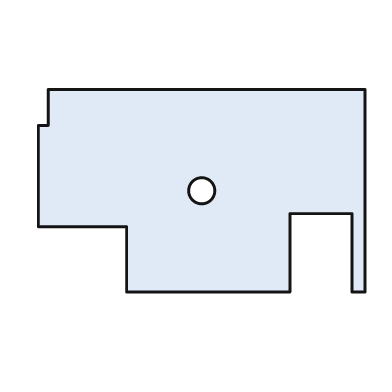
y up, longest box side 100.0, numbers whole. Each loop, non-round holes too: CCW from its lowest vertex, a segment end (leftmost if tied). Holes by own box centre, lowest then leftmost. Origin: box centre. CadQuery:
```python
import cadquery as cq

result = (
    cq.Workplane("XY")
    .moveTo(-23.0, -31.0)
    .lineTo(27.0, -31.0)
    .lineTo(27.0, -7.0)
    .lineTo(46.0, -7.0)
    .lineTo(46.0, -31.0)
    .lineTo(50.0, -31.0)
    .lineTo(50.0, 31.0)
    .lineTo(-47.0, 31.0)
    .lineTo(-47.0, 20.0)
    .lineTo(-50.0, 20.0)
    .lineTo(-50.0, -11.0)
    .lineTo(-23.0, -11.0)
    .close()
    .moveTo(0.0, 0.0)
    .circle(4.0)
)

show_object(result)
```